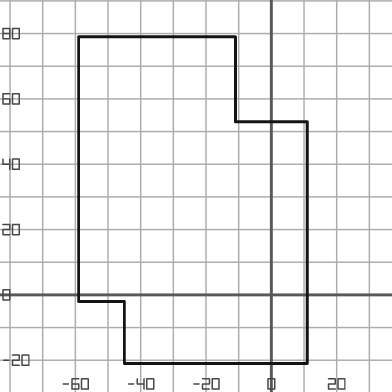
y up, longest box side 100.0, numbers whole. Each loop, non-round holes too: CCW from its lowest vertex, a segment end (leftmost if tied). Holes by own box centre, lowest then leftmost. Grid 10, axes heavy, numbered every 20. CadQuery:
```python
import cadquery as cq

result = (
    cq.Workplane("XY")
    .moveTo(-45.0, -21.0)
    .lineTo(11.0, -21.0)
    .lineTo(11.0, 53.0)
    .lineTo(-11.0, 53.0)
    .lineTo(-11.0, 79.0)
    .lineTo(-59.0, 79.0)
    .lineTo(-59.0, -2.0)
    .lineTo(-45.0, -2.0)
    .close()
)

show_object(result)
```